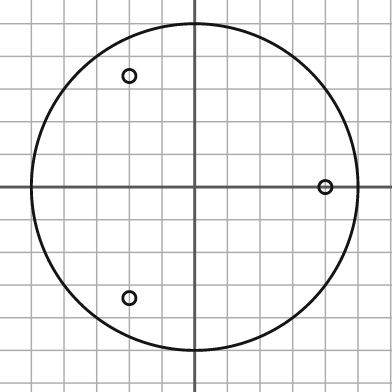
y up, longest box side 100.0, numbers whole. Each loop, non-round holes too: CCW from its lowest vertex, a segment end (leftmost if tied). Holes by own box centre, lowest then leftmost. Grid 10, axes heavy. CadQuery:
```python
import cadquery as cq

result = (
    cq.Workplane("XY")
    .moveTo(0.0, 0.0)
    .circle(50.0)
    .moveTo(-20.0, -34.0)
    .circle(2.0)
    .moveTo(40.0, 0.0)
    .circle(2.0)
    .moveTo(-20.0, 34.0)
    .circle(2.0)
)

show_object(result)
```